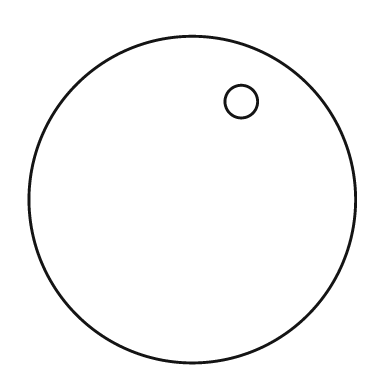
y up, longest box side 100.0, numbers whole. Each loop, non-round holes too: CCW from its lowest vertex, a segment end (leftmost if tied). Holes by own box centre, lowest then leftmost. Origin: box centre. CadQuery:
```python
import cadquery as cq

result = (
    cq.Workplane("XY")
    .moveTo(0.0, 0.0)
    .circle(50.0)
    .moveTo(15.0, 30.0)
    .circle(5.0)
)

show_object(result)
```